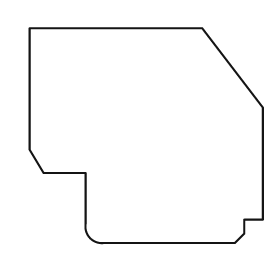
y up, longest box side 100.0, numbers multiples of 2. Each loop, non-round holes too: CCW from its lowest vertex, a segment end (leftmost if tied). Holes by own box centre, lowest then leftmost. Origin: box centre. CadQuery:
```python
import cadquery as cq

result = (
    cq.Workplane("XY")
    .moveTo(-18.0, -46.0)
    .lineTo(38.0, -46.0)
    .lineTo(42.0, -42.0)
    .lineTo(42.0, -36.0)
    .lineTo(50.0, -36.0)
    .lineTo(50.0, 12.0)
    .lineTo(24.0, 46.0)
    .lineTo(-50.0, 46.0)
    .lineTo(-50.0, -6.0)
    .lineTo(-44.0, -16.0)
    .lineTo(-26.0, -16.0)
    .lineTo(-26.0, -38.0)
    .threePointArc((-24.0, -44.0), (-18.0, -46.0))
    .close()
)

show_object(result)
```